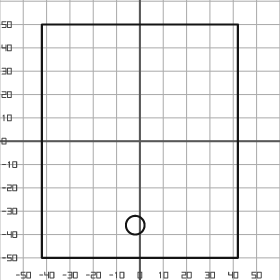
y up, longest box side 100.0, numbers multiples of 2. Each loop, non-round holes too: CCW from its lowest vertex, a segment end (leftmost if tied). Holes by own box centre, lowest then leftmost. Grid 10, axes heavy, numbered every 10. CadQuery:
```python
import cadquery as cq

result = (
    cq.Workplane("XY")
    .moveTo(-42.0, -50.0)
    .lineTo(42.0, -50.0)
    .lineTo(42.0, 50.0)
    .lineTo(-42.0, 50.0)
    .close()
    .moveTo(-2.0, -36.0)
    .circle(4.0)
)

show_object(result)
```